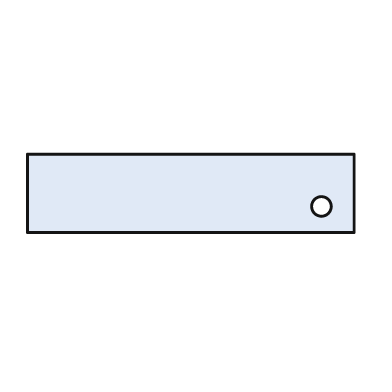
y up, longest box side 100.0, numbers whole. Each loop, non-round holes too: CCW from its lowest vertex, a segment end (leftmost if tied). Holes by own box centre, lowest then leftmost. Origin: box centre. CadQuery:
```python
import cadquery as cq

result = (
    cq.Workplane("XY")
    .moveTo(-50.0, -12.0)
    .lineTo(50.0, -12.0)
    .lineTo(50.0, 12.0)
    .lineTo(-50.0, 12.0)
    .close()
    .moveTo(40.0, -4.0)
    .circle(3.0)
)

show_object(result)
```